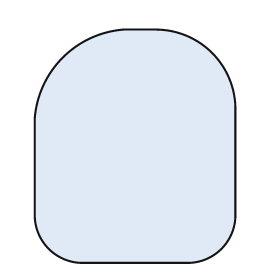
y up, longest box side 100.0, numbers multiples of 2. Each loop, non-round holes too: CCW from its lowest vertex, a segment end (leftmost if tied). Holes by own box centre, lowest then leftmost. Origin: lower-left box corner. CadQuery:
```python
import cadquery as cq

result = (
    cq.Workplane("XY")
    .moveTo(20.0, 0.0)
    .lineTo(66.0, 0.0)
    .threePointArc((80.0, 6.0), (86.0, 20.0))
    .lineTo(86.0, 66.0)
    .threePointArc((76.0, 90.0), (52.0, 100.0))
    .lineTo(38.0, 100.0)
    .threePointArc((12.0, 88.0), (0.0, 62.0))
    .lineTo(0.0, 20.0)
    .threePointArc((6.0, 6.0), (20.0, 0.0))
    .close()
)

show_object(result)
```